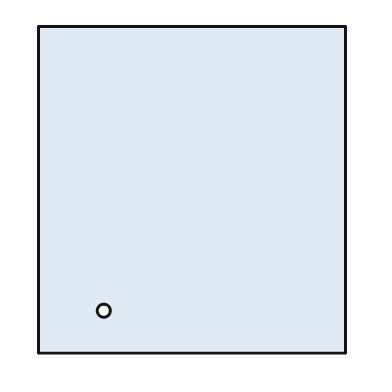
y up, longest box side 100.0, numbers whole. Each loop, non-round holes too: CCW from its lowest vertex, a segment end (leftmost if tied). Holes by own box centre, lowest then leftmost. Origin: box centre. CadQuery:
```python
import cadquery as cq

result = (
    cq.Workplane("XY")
    .moveTo(-47.0, -50.0)
    .lineTo(47.0, -50.0)
    .lineTo(47.0, 50.0)
    .lineTo(-47.0, 50.0)
    .close()
    .moveTo(-27.0, -37.0)
    .circle(2.0)
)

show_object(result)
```